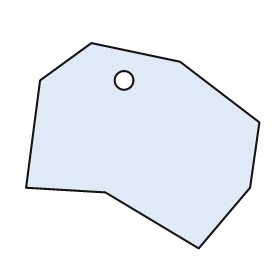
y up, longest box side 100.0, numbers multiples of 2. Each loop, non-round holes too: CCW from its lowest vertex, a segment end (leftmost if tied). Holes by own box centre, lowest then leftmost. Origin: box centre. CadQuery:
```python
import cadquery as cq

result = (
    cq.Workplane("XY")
    .moveTo(24.0, -44.0)
    .lineTo(46.0, -18.0)
    .lineTo(50.0, 10.0)
    .lineTo(16.0, 36.0)
    .lineTo(-22.0, 44.0)
    .lineTo(-44.0, 28.0)
    .lineTo(-50.0, -18.0)
    .lineTo(-16.0, -20.0)
    .close()
    .moveTo(-8.0, 28.0)
    .circle(4.0)
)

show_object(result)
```